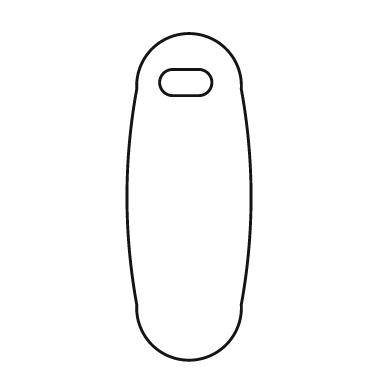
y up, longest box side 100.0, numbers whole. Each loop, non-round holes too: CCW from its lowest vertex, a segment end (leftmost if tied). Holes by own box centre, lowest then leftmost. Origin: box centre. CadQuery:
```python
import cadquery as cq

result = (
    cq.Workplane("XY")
    .moveTo(-16.0, -33.0)
    .threePointArc((0.0, -50.0), (16.0, -33.0))
    .threePointArc((19.0, 0.0), (16.0, 33.0))
    .threePointArc((0.0, 50.0), (-16.0, 33.0))
    .threePointArc((-19.0, 0.0), (-16.0, -33.0))
    .close()
    .moveTo(-5.0, 31.0)
    .lineTo(3.0, 31.0)
    .threePointArc((7.0, 35.0), (3.0, 39.0))
    .lineTo(-5.0, 39.0)
    .threePointArc((-9.0, 35.0), (-5.0, 31.0))
    .close()
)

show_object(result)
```